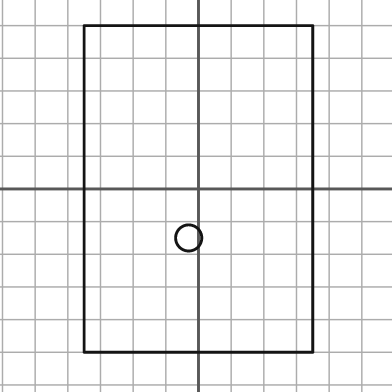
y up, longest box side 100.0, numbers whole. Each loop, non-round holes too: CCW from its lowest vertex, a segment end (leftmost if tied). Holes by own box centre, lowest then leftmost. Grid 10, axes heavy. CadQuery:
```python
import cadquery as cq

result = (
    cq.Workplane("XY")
    .moveTo(-35.0, -50.0)
    .lineTo(35.0, -50.0)
    .lineTo(35.0, 50.0)
    .lineTo(-35.0, 50.0)
    .close()
    .moveTo(-3.0, -15.0)
    .circle(4.0)
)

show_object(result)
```